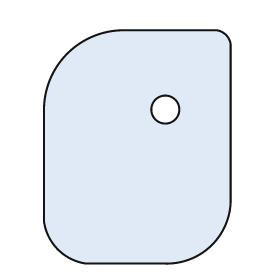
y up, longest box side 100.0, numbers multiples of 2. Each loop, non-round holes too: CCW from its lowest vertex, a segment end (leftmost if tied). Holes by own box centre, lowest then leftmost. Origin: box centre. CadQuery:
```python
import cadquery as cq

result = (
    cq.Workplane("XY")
    .moveTo(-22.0, -50.0)
    .lineTo(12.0, -50.0)
    .threePointArc((32.0, -42.0), (40.0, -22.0))
    .lineTo(40.0, 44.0)
    .threePointArc((38.0, 48.0), (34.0, 50.0))
    .lineTo(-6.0, 50.0)
    .threePointArc((-30.0, 40.0), (-40.0, 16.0))
    .lineTo(-40.0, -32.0)
    .threePointArc((-34.0, -44.0), (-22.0, -50.0))
    .close()
    .moveTo(12.0, 16.0)
    .circle(6.0)
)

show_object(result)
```